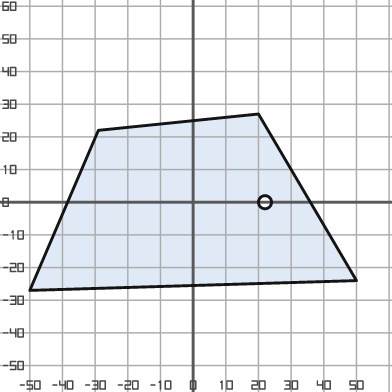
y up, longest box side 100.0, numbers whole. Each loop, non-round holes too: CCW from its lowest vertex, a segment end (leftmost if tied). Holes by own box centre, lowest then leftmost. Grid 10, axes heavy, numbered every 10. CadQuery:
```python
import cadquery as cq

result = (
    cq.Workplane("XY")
    .moveTo(-50.0, -27.0)
    .lineTo(50.0, -24.0)
    .lineTo(20.0, 27.0)
    .lineTo(-29.0, 22.0)
    .close()
    .moveTo(22.0, 0.0)
    .circle(2.0)
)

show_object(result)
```